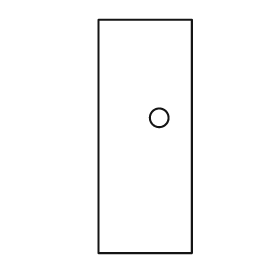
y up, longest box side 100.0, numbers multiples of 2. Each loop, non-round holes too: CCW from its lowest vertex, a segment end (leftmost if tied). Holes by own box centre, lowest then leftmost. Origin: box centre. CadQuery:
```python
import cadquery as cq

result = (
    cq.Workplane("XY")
    .moveTo(-20.0, -50.0)
    .lineTo(20.0, -50.0)
    .lineTo(20.0, 50.0)
    .lineTo(-20.0, 50.0)
    .close()
    .moveTo(6.0, 8.0)
    .circle(4.0)
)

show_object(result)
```